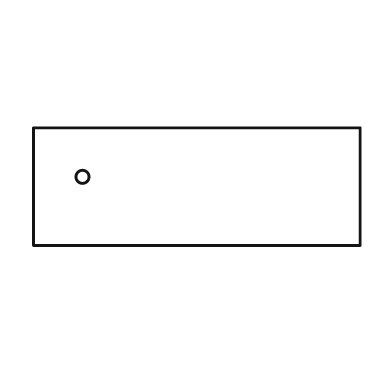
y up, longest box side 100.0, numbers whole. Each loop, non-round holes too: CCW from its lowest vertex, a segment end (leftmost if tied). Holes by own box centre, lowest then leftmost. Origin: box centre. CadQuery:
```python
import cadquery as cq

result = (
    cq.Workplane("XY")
    .moveTo(-50.0, -18.0)
    .lineTo(50.0, -18.0)
    .lineTo(50.0, 18.0)
    .lineTo(-50.0, 18.0)
    .close()
    .moveTo(-35.0, 3.0)
    .circle(2.0)
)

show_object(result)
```